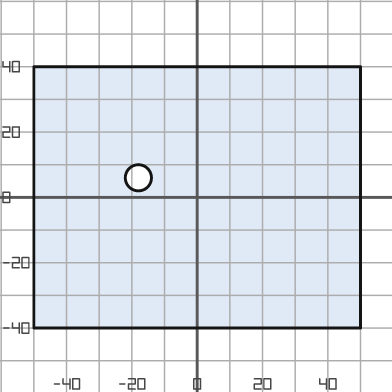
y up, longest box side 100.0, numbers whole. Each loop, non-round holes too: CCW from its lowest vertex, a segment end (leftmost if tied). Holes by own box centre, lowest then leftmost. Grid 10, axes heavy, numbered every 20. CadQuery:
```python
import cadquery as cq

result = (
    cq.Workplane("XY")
    .moveTo(-50.0, -40.0)
    .lineTo(50.0, -40.0)
    .lineTo(50.0, 40.0)
    .lineTo(-50.0, 40.0)
    .close()
    .moveTo(-18.0, 6.0)
    .circle(4.0)
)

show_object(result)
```